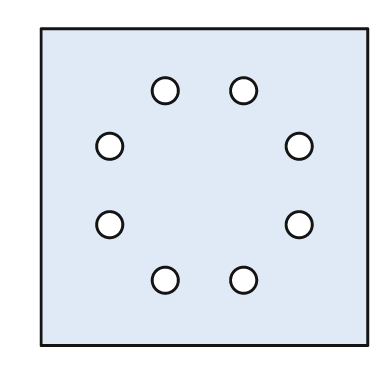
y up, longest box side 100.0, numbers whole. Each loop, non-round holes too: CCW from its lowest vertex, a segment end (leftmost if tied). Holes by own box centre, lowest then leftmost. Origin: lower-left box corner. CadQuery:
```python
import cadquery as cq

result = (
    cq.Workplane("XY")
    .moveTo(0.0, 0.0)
    .lineTo(100.0, 0.0)
    .lineTo(100.0, 97.0)
    .lineTo(0.0, 97.0)
    .close()
    .moveTo(38.0, 20.0)
    .circle(4.0)
    .moveTo(62.0, 20.0)
    .circle(4.0)
    .moveTo(21.0, 37.0)
    .circle(4.0)
    .moveTo(79.0, 37.0)
    .circle(4.0)
    .moveTo(21.0, 61.0)
    .circle(4.0)
    .moveTo(79.0, 61.0)
    .circle(4.0)
    .moveTo(38.0, 78.0)
    .circle(4.0)
    .moveTo(62.0, 78.0)
    .circle(4.0)
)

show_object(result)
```